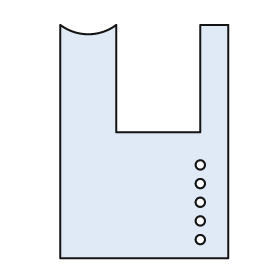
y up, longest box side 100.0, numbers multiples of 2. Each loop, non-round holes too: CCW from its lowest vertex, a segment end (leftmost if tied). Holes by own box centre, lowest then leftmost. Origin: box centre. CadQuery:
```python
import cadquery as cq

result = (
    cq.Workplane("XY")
    .moveTo(-36.0, -50.0)
    .lineTo(36.0, -50.0)
    .lineTo(36.0, 50.0)
    .lineTo(24.0, 50.0)
    .lineTo(24.0, 4.0)
    .lineTo(-12.0, 4.0)
    .lineTo(-12.0, 50.0)
    .threePointArc((-24.0, 46.0), (-36.0, 50.0))
    .close()
    .moveTo(24.0, -42.0)
    .circle(2.0)
    .moveTo(24.0, -34.0)
    .circle(2.0)
    .moveTo(24.0, -26.0)
    .circle(2.0)
    .moveTo(24.0, -18.0)
    .circle(2.0)
    .moveTo(24.0, -10.0)
    .circle(2.0)
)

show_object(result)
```